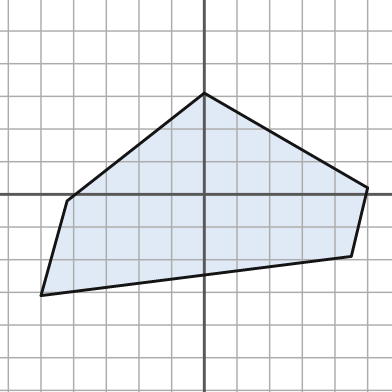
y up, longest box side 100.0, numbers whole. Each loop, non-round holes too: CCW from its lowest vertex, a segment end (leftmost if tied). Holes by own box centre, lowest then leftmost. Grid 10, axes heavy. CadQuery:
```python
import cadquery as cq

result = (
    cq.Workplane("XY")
    .moveTo(-50.0, -31.0)
    .lineTo(45.0, -19.0)
    .lineTo(50.0, 2.0)
    .lineTo(0.0, 31.0)
    .lineTo(-42.0, -2.0)
    .close()
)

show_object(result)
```